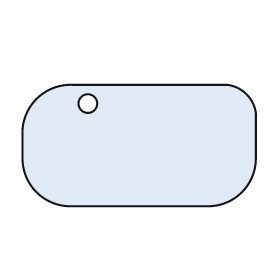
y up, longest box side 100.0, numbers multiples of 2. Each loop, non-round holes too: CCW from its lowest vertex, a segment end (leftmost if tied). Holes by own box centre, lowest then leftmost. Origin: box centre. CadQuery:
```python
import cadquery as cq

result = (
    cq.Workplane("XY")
    .moveTo(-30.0, -26.0)
    .lineTo(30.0, -26.0)
    .threePointArc((44.0, -20.0), (50.0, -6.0))
    .lineTo(50.0, 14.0)
    .threePointArc((46.0, 22.0), (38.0, 26.0))
    .lineTo(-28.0, 26.0)
    .threePointArc((-44.0, 20.0), (-50.0, 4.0))
    .lineTo(-50.0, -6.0)
    .threePointArc((-44.0, -20.0), (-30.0, -26.0))
    .close()
    .moveTo(-22.0, 18.0)
    .circle(4.0)
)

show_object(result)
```